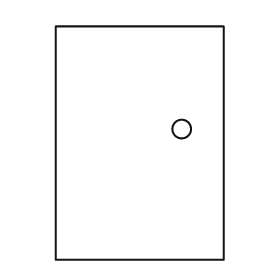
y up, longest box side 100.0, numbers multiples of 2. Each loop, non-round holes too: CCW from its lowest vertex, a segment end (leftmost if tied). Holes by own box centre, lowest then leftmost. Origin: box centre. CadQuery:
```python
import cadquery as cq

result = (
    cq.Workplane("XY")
    .moveTo(-36.0, -50.0)
    .lineTo(36.0, -50.0)
    .lineTo(36.0, 50.0)
    .lineTo(-36.0, 50.0)
    .close()
    .moveTo(18.0, 6.0)
    .circle(4.0)
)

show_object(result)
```